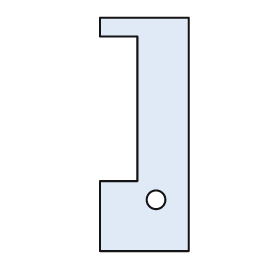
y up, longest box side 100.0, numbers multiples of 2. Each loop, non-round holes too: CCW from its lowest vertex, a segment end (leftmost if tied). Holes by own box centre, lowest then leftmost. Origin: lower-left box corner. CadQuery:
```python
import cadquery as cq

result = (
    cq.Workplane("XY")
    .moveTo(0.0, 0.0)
    .lineTo(38.0, 0.0)
    .lineTo(38.0, 100.0)
    .lineTo(0.0, 100.0)
    .lineTo(0.0, 92.0)
    .lineTo(16.0, 92.0)
    .lineTo(16.0, 30.0)
    .lineTo(0.0, 30.0)
    .close()
    .moveTo(24.0, 22.0)
    .circle(4.0)
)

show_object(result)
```